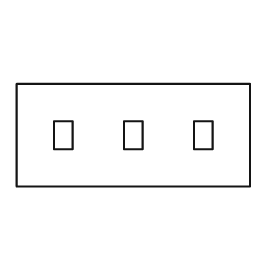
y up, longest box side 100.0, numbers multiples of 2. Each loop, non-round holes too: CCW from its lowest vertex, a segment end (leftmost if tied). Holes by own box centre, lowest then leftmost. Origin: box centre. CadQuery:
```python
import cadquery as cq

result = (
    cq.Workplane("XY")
    .moveTo(-50.0, -22.0)
    .lineTo(50.0, -22.0)
    .lineTo(50.0, 22.0)
    .lineTo(-50.0, 22.0)
    .close()
    .moveTo(-34.0, -6.0)
    .lineTo(-26.0, -6.0)
    .lineTo(-26.0, 6.0)
    .lineTo(-34.0, 6.0)
    .close()
    .moveTo(-4.0, -6.0)
    .lineTo(4.0, -6.0)
    .lineTo(4.0, 6.0)
    .lineTo(-4.0, 6.0)
    .close()
    .moveTo(26.0, -6.0)
    .lineTo(34.0, -6.0)
    .lineTo(34.0, 6.0)
    .lineTo(26.0, 6.0)
    .close()
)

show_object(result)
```